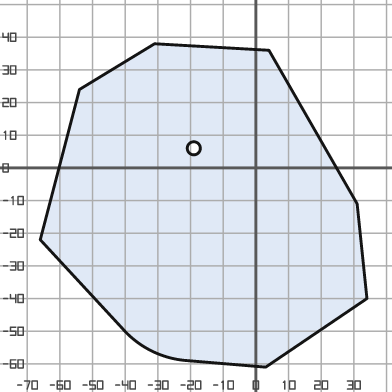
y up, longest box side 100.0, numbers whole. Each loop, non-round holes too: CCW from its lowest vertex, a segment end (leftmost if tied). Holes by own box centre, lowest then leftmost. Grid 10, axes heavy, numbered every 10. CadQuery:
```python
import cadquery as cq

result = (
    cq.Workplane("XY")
    .moveTo(3.0, -61.0)
    .lineTo(34.0, -40.0)
    .lineTo(31.0, -11.0)
    .lineTo(4.0, 36.0)
    .lineTo(-31.0, 38.0)
    .lineTo(-54.0, 24.0)
    .lineTo(-66.0, -22.0)
    .lineTo(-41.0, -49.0)
    .threePointArc((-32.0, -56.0), (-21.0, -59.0))
    .close()
    .moveTo(-19.0, 6.0)
    .circle(2.0)
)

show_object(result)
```